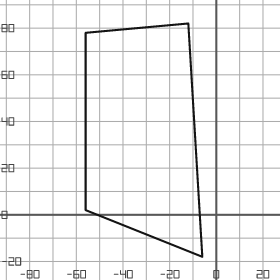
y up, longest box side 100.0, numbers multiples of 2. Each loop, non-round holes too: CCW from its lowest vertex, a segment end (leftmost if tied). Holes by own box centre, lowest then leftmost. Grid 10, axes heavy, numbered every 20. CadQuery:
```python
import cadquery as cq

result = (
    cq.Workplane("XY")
    .moveTo(-6.0, -18.0)
    .lineTo(-12.0, 82.0)
    .lineTo(-56.0, 78.0)
    .lineTo(-56.0, 2.0)
    .close()
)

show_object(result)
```